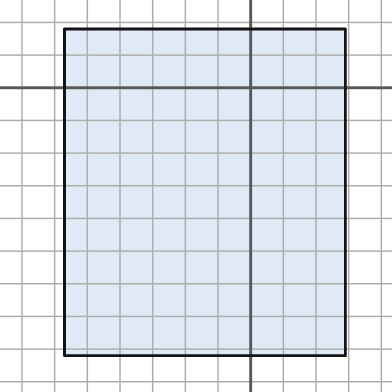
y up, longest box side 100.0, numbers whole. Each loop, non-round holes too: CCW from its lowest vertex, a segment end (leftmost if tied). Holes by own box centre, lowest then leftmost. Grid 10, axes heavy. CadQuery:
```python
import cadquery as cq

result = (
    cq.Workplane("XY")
    .moveTo(-57.0, -82.0)
    .lineTo(29.0, -82.0)
    .lineTo(29.0, 18.0)
    .lineTo(-57.0, 18.0)
    .close()
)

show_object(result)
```